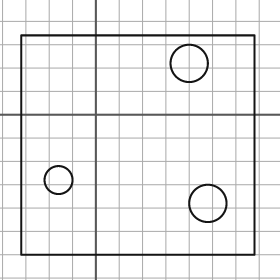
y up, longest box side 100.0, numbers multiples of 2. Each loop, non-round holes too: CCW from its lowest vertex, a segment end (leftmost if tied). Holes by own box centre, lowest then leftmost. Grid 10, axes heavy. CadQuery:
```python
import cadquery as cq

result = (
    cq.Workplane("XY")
    .moveTo(-32.0, -60.0)
    .lineTo(68.0, -60.0)
    .lineTo(68.0, 34.0)
    .lineTo(-32.0, 34.0)
    .close()
    .moveTo(48.0, -38.0)
    .circle(8.0)
    .moveTo(-16.0, -28.0)
    .circle(6.0)
    .moveTo(40.0, 22.0)
    .circle(8.0)
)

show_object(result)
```